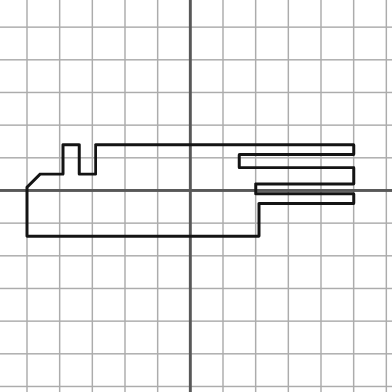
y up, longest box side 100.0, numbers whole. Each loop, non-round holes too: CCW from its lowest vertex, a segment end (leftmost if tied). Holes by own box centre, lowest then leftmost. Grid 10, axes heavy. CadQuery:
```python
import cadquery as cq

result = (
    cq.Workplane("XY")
    .moveTo(-50.0, -14.0)
    .lineTo(21.0, -14.0)
    .lineTo(21.0, -4.0)
    .lineTo(50.0, -4.0)
    .lineTo(50.0, -1.0)
    .lineTo(20.0, -1.0)
    .lineTo(20.0, 2.0)
    .lineTo(50.0, 2.0)
    .lineTo(50.0, 7.0)
    .lineTo(15.0, 7.0)
    .lineTo(15.0, 11.0)
    .lineTo(50.0, 11.0)
    .lineTo(50.0, 14.0)
    .lineTo(-29.0, 14.0)
    .lineTo(-29.0, 5.0)
    .lineTo(-34.0, 5.0)
    .lineTo(-34.0, 14.0)
    .lineTo(-39.0, 14.0)
    .lineTo(-39.0, 5.0)
    .lineTo(-46.0, 5.0)
    .lineTo(-50.0, 1.0)
    .close()
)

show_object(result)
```